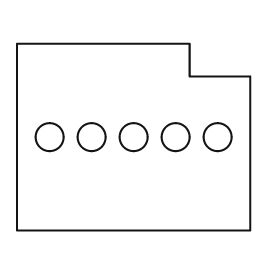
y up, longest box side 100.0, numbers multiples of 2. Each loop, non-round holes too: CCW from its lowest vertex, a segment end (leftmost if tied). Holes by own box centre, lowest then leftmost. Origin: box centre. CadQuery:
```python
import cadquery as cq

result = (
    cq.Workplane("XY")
    .moveTo(-50.0, -40.0)
    .lineTo(50.0, -40.0)
    .lineTo(50.0, 26.0)
    .lineTo(24.0, 26.0)
    .lineTo(24.0, 40.0)
    .lineTo(-50.0, 40.0)
    .close()
    .moveTo(-36.0, 0.0)
    .circle(6.0)
    .moveTo(-18.0, 0.0)
    .circle(6.0)
    .moveTo(0.0, 0.0)
    .circle(6.0)
    .moveTo(18.0, 0.0)
    .circle(6.0)
    .moveTo(36.0, 0.0)
    .circle(6.0)
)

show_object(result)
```